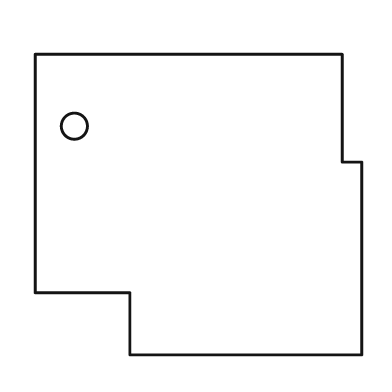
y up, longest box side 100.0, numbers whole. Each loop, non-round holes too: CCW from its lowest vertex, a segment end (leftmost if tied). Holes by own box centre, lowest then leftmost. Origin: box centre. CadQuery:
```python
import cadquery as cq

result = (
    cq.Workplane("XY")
    .moveTo(-21.0, -46.0)
    .lineTo(50.0, -46.0)
    .lineTo(50.0, 13.0)
    .lineTo(44.0, 13.0)
    .lineTo(44.0, 46.0)
    .lineTo(-50.0, 46.0)
    .lineTo(-50.0, -27.0)
    .lineTo(-21.0, -27.0)
    .close()
    .moveTo(-38.0, 24.0)
    .circle(4.0)
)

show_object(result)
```